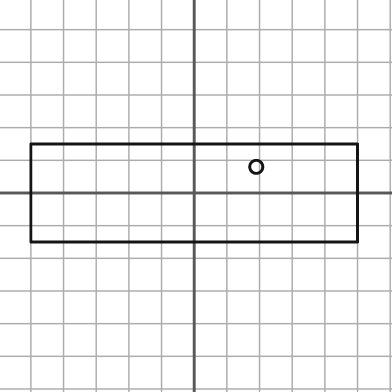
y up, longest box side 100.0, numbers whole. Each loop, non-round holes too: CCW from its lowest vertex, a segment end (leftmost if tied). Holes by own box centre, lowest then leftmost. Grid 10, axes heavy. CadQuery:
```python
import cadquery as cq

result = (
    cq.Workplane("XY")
    .moveTo(-50.0, -15.0)
    .lineTo(50.0, -15.0)
    .lineTo(50.0, 15.0)
    .lineTo(-50.0, 15.0)
    .close()
    .moveTo(19.0, 8.0)
    .circle(2.0)
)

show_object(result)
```